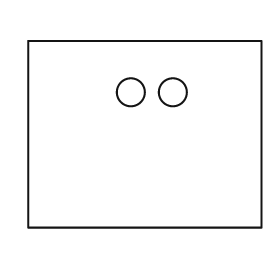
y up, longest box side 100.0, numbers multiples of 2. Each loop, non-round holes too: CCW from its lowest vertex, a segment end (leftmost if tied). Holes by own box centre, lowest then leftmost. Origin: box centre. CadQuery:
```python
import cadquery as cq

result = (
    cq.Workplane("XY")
    .moveTo(-50.0, -40.0)
    .lineTo(50.0, -40.0)
    .lineTo(50.0, 40.0)
    .lineTo(-50.0, 40.0)
    .close()
    .moveTo(-6.0, 18.0)
    .circle(6.0)
    .moveTo(12.0, 18.0)
    .circle(6.0)
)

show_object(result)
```